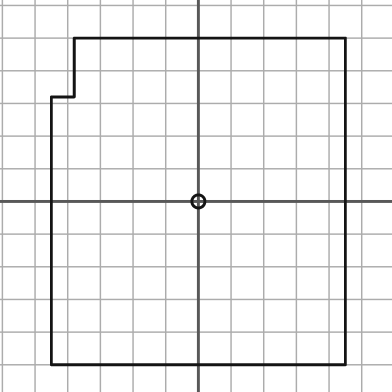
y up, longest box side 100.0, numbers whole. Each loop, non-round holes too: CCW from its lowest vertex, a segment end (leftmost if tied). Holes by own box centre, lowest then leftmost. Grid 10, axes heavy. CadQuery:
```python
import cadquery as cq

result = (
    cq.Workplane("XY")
    .moveTo(-45.0, -50.0)
    .lineTo(45.0, -50.0)
    .lineTo(45.0, 50.0)
    .lineTo(-38.0, 50.0)
    .lineTo(-38.0, 32.0)
    .lineTo(-45.0, 32.0)
    .close()
    .moveTo(0.0, 0.0)
    .circle(2.0)
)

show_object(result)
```